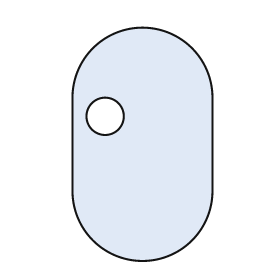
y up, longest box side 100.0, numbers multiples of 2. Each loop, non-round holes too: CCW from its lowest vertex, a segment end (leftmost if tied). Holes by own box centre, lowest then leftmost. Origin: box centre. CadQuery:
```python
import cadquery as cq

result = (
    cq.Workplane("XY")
    .moveTo(-30.0, -20.0)
    .threePointArc((0.0, -50.0), (30.0, -20.0))
    .lineTo(30.0, 20.0)
    .threePointArc((0.0, 50.0), (-30.0, 20.0))
    .close()
    .moveTo(-16.0, 12.0)
    .circle(8.0)
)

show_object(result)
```